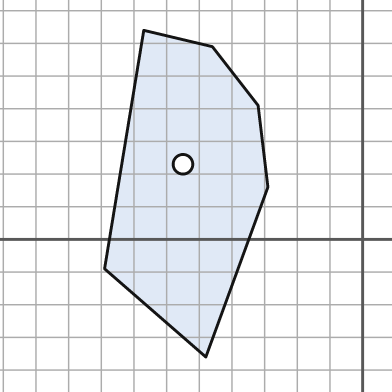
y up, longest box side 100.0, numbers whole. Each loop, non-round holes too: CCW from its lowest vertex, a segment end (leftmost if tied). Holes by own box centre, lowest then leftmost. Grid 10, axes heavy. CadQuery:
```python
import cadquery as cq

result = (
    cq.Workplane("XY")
    .moveTo(-48.0, -36.0)
    .lineTo(-29.0, 16.0)
    .lineTo(-32.0, 41.0)
    .lineTo(-46.0, 59.0)
    .lineTo(-67.0, 64.0)
    .lineTo(-79.0, -9.0)
    .close()
    .moveTo(-55.0, 23.0)
    .circle(3.0)
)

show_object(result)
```